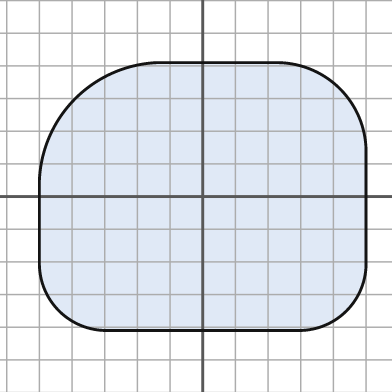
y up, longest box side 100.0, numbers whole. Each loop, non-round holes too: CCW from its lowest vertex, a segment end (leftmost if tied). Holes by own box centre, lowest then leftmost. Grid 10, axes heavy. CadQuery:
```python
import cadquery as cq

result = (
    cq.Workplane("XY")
    .moveTo(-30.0, -41.0)
    .lineTo(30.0, -41.0)
    .threePointArc((44.0, -35.0), (50.0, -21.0))
    .lineTo(50.0, 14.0)
    .threePointArc((42.0, 33.0), (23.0, 41.0))
    .lineTo(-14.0, 41.0)
    .threePointArc((-39.0, 30.0), (-50.0, 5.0))
    .lineTo(-50.0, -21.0)
    .threePointArc((-44.0, -35.0), (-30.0, -41.0))
    .close()
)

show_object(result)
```